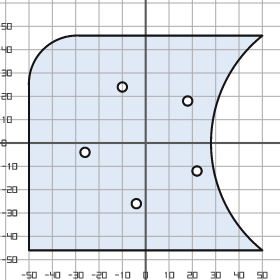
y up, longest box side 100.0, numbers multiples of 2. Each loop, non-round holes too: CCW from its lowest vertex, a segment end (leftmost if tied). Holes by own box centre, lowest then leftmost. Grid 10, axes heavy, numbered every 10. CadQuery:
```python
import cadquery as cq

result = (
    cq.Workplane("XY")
    .moveTo(-50.0, -46.0)
    .lineTo(50.0, -46.0)
    .threePointArc((28.0, 0.0), (50.0, 46.0))
    .lineTo(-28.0, 46.0)
    .threePointArc((-44.0, 40.0), (-50.0, 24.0))
    .close()
    .moveTo(-4.0, -26.0)
    .circle(2.0)
    .moveTo(22.0, -12.0)
    .circle(2.0)
    .moveTo(-26.0, -4.0)
    .circle(2.0)
    .moveTo(18.0, 18.0)
    .circle(2.0)
    .moveTo(-10.0, 24.0)
    .circle(2.0)
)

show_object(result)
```